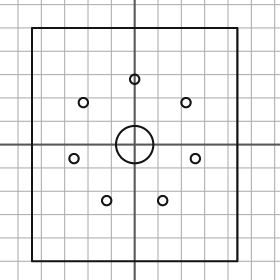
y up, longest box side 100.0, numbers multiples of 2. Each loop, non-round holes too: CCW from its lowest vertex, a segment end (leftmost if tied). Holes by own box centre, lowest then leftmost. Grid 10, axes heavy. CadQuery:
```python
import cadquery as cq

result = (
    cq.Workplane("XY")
    .moveTo(-44.0, -50.0)
    .lineTo(44.0, -50.0)
    .lineTo(44.0, 50.0)
    .lineTo(-44.0, 50.0)
    .close()
    .moveTo(-12.0, -24.0)
    .circle(2.0)
    .moveTo(12.0, -24.0)
    .circle(2.0)
    .moveTo(-26.0, -6.0)
    .circle(2.0)
    .moveTo(26.0, -6.0)
    .circle(2.0)
    .moveTo(0.0, 0.0)
    .circle(8.0)
    .moveTo(-22.0, 18.0)
    .circle(2.0)
    .moveTo(22.0, 18.0)
    .circle(2.0)
    .moveTo(0.0, 28.0)
    .circle(2.0)
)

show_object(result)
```